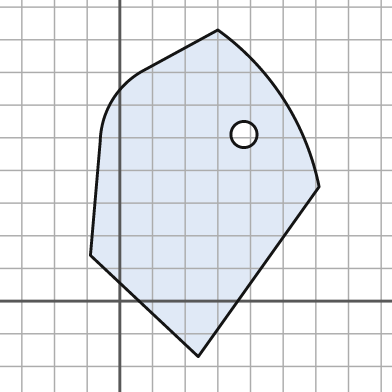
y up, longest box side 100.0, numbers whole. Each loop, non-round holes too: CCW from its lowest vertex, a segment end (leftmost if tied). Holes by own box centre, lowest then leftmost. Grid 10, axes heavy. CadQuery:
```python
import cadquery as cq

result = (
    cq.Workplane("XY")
    .moveTo(24.0, -17.0)
    .lineTo(61.0, 35.0)
    .threePointArc((50.0, 62.0), (30.0, 83.0))
    .lineTo(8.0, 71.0)
    .threePointArc((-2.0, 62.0), (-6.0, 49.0))
    .lineTo(-9.0, 14.0)
    .close()
    .moveTo(38.0, 51.0)
    .circle(4.0)
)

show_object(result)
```